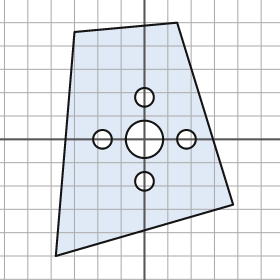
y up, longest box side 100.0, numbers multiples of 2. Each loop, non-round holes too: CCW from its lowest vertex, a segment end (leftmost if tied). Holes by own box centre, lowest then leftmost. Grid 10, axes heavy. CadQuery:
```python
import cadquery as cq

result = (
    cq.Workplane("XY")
    .moveTo(-38.0, -50.0)
    .lineTo(38.0, -28.0)
    .lineTo(14.0, 50.0)
    .lineTo(-30.0, 46.0)
    .close()
    .moveTo(0.0, -18.0)
    .circle(4.0)
    .moveTo(-18.0, 0.0)
    .circle(4.0)
    .moveTo(0.0, 0.0)
    .circle(8.0)
    .moveTo(18.0, 0.0)
    .circle(4.0)
    .moveTo(0.0, 18.0)
    .circle(4.0)
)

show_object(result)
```